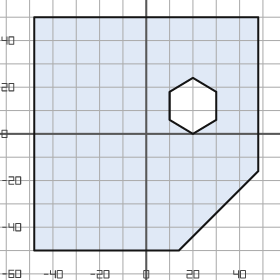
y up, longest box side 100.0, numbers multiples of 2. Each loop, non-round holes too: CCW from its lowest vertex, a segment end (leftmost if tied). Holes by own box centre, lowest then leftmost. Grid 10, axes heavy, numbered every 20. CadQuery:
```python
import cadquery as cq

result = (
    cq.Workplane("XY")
    .moveTo(-48.0, -50.0)
    .lineTo(14.0, -50.0)
    .lineTo(48.0, -16.0)
    .lineTo(48.0, 50.0)
    .lineTo(-48.0, 50.0)
    .close()
    .moveTo(20.0, 0.0)
    .lineTo(30.0, 6.0)
    .lineTo(30.0, 18.0)
    .lineTo(20.0, 24.0)
    .lineTo(10.0, 18.0)
    .lineTo(10.0, 6.0)
    .close()
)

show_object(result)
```